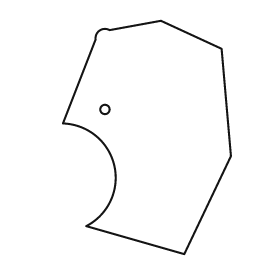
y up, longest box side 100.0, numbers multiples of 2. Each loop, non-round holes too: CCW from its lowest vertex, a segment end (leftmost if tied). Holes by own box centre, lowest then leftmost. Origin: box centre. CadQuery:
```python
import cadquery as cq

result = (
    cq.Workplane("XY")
    .moveTo(16.0, -50.0)
    .lineTo(36.0, -8.0)
    .lineTo(32.0, 38.0)
    .lineTo(6.0, 50.0)
    .lineTo(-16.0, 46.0)
    .threePointArc((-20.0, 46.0), (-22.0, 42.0))
    .lineTo(-36.0, 6.0)
    .threePointArc((-14.0, -12.0), (-26.0, -38.0))
    .close()
    .moveTo(-18.0, 12.0)
    .circle(2.0)
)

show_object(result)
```